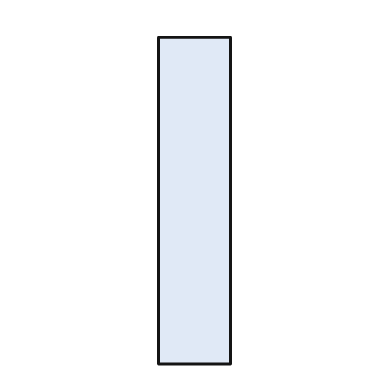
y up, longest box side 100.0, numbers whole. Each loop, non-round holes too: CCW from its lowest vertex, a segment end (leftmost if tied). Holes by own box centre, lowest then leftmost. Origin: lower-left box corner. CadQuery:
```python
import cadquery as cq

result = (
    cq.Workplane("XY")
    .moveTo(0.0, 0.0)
    .lineTo(22.0, 0.0)
    .lineTo(22.0, 100.0)
    .lineTo(0.0, 100.0)
    .close()
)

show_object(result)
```